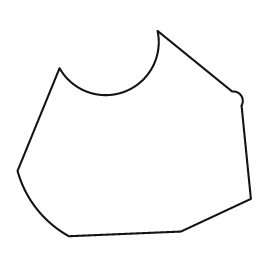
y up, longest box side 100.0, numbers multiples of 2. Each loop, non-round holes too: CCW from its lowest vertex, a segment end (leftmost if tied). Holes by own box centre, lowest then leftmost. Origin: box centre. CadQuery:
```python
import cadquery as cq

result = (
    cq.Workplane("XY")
    .moveTo(-28.0, -44.0)
    .lineTo(20.0, -42.0)
    .lineTo(50.0, -28.0)
    .lineTo(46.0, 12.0)
    .threePointArc((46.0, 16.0), (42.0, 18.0))
    .lineTo(10.0, 44.0)
    .threePointArc((-4.0, 18.0), (-32.0, 28.0))
    .lineTo(-50.0, -16.0)
    .threePointArc((-42.0, -32.0), (-28.0, -44.0))
    .close()
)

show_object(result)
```